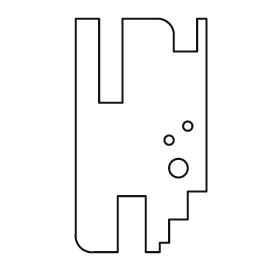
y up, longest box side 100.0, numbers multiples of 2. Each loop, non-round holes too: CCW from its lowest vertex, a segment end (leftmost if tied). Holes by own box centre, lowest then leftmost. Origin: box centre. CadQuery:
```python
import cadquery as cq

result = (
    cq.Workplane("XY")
    .moveTo(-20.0, -50.0)
    .lineTo(-10.0, -50.0)
    .lineTo(-10.0, -26.0)
    .lineTo(2.0, -26.0)
    .lineTo(2.0, -50.0)
    .lineTo(8.0, -50.0)
    .lineTo(8.0, -46.0)
    .lineTo(12.0, -46.0)
    .lineTo(12.0, -36.0)
    .lineTo(20.0, -36.0)
    .lineTo(20.0, -24.0)
    .lineTo(28.0, -24.0)
    .lineTo(28.0, 50.0)
    .lineTo(24.0, 50.0)
    .lineTo(24.0, 36.0)
    .lineTo(14.0, 36.0)
    .lineTo(14.0, 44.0)
    .threePointArc((12.0, 48.0), (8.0, 50.0))
    .lineTo(-8.0, 50.0)
    .lineTo(-8.0, 14.0)
    .lineTo(-18.0, 14.0)
    .lineTo(-18.0, 50.0)
    .lineTo(-28.0, 50.0)
    .lineTo(-28.0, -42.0)
    .threePointArc((-26.0, -48.0), (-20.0, -50.0))
    .close()
    .moveTo(16.0, -14.0)
    .circle(4.0)
    .moveTo(12.0, -2.0)
    .circle(2.0)
    .moveTo(20.0, 4.0)
    .circle(2.0)
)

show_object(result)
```